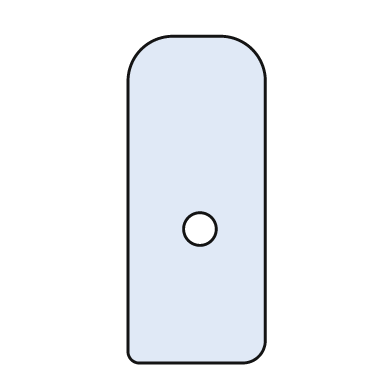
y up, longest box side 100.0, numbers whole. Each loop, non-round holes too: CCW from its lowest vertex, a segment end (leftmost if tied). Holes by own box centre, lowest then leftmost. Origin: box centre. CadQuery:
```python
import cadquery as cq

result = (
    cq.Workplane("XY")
    .moveTo(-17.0, -50.0)
    .lineTo(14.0, -50.0)
    .threePointArc((19.0, -48.0), (21.0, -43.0))
    .lineTo(21.0, 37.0)
    .threePointArc((17.0, 46.0), (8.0, 50.0))
    .lineTo(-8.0, 50.0)
    .threePointArc((-17.0, 46.0), (-21.0, 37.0))
    .lineTo(-21.0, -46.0)
    .threePointArc((-20.0, -49.0), (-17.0, -50.0))
    .close()
    .moveTo(1.0, -9.0)
    .circle(5.0)
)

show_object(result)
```